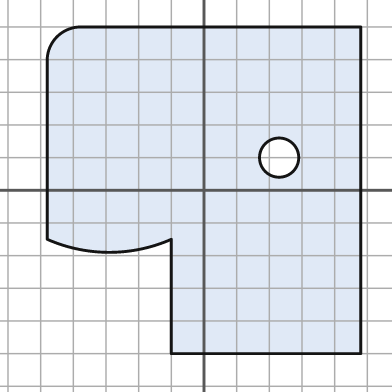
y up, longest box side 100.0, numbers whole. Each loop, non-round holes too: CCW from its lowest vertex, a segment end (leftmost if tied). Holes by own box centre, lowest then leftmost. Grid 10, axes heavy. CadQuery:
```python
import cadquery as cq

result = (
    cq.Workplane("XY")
    .moveTo(-10.0, -50.0)
    .lineTo(48.0, -50.0)
    .lineTo(48.0, 50.0)
    .lineTo(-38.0, 50.0)
    .threePointArc((-45.0, 47.0), (-48.0, 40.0))
    .lineTo(-48.0, -15.0)
    .threePointArc((-29.0, -19.0), (-10.0, -15.0))
    .close()
    .moveTo(23.0, 10.0)
    .circle(6.0)
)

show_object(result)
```